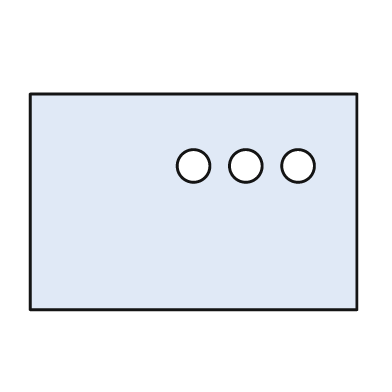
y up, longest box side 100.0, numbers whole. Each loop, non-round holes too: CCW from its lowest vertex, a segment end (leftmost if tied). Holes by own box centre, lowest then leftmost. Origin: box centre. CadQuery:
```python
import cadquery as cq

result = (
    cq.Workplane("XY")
    .moveTo(-50.0, -33.0)
    .lineTo(50.0, -33.0)
    .lineTo(50.0, 33.0)
    .lineTo(-50.0, 33.0)
    .close()
    .moveTo(0.0, 11.0)
    .circle(5.0)
    .moveTo(16.0, 11.0)
    .circle(5.0)
    .moveTo(32.0, 11.0)
    .circle(5.0)
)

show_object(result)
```